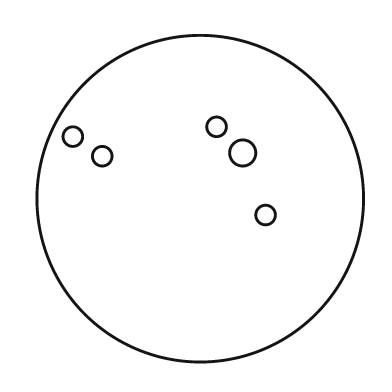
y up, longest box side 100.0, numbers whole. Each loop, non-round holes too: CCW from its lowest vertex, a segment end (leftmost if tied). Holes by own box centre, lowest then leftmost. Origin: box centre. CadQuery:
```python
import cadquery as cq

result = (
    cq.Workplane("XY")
    .moveTo(0.0, 0.0)
    .circle(50.0)
    .moveTo(20.0, -5.0)
    .circle(3.0)
    .moveTo(-30.0, 13.0)
    .circle(3.0)
    .moveTo(13.0, 14.0)
    .circle(4.0)
    .moveTo(-39.0, 19.0)
    .circle(3.0)
    .moveTo(5.0, 22.0)
    .circle(3.0)
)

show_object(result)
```